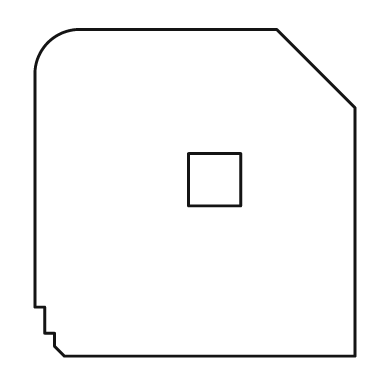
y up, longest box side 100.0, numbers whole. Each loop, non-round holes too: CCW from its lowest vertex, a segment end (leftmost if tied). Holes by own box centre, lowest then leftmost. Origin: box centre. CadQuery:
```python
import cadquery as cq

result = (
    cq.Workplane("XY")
    .moveTo(-40.0, -50.0)
    .lineTo(49.0, -50.0)
    .lineTo(49.0, 26.0)
    .lineTo(25.0, 50.0)
    .lineTo(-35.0, 50.0)
    .threePointArc((-45.0, 46.0), (-49.0, 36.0))
    .lineTo(-49.0, -35.0)
    .lineTo(-46.0, -35.0)
    .lineTo(-46.0, -43.0)
    .lineTo(-43.0, -43.0)
    .lineTo(-43.0, -47.0)
    .close()
    .moveTo(-2.0, -4.0)
    .lineTo(14.0, -4.0)
    .lineTo(14.0, 12.0)
    .lineTo(-2.0, 12.0)
    .close()
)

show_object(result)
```